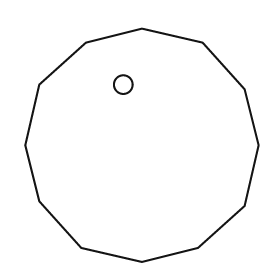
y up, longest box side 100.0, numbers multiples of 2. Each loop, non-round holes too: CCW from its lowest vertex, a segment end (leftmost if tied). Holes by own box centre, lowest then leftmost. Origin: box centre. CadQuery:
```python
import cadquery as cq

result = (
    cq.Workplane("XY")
    .moveTo(0.0, -50.0)
    .lineTo(24.0, -44.0)
    .lineTo(44.0, -26.0)
    .lineTo(50.0, 0.0)
    .lineTo(44.0, 24.0)
    .lineTo(26.0, 44.0)
    .lineTo(0.0, 50.0)
    .lineTo(-24.0, 44.0)
    .lineTo(-44.0, 26.0)
    .lineTo(-50.0, 0.0)
    .lineTo(-44.0, -24.0)
    .lineTo(-26.0, -44.0)
    .close()
    .moveTo(-8.0, 26.0)
    .circle(4.0)
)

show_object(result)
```